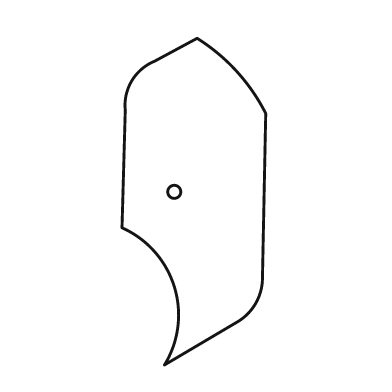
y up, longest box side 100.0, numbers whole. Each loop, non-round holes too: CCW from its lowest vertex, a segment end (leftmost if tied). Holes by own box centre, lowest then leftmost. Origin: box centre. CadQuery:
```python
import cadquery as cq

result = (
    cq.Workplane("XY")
    .moveTo(-9.0, -50.0)
    .lineTo(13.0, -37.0)
    .threePointArc((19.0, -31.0), (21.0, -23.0))
    .lineTo(22.0, 27.0)
    .threePointArc((13.0, 40.0), (1.0, 50.0))
    .lineTo(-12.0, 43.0)
    .threePointArc((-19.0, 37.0), (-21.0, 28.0))
    .lineTo(-22.0, -8.0)
    .threePointArc((-6.0, -26.0), (-9.0, -50.0))
    .close()
    .moveTo(-6.0, 3.0)
    .circle(2.0)
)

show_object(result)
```